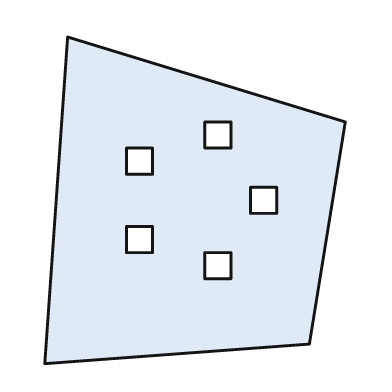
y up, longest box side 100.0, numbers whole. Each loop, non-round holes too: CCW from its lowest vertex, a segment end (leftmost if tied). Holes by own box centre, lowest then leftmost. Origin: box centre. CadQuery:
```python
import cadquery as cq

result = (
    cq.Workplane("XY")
    .moveTo(-46.0, -50.0)
    .lineTo(35.0, -44.0)
    .lineTo(46.0, 24.0)
    .lineTo(-39.0, 50.0)
    .close()
    .moveTo(3.0, -24.0)
    .lineTo(11.0, -24.0)
    .lineTo(11.0, -16.0)
    .lineTo(3.0, -16.0)
    .close()
    .moveTo(-21.0, -16.0)
    .lineTo(-13.0, -16.0)
    .lineTo(-13.0, -8.0)
    .lineTo(-21.0, -8.0)
    .close()
    .moveTo(17.0, -4.0)
    .lineTo(25.0, -4.0)
    .lineTo(25.0, 4.0)
    .lineTo(17.0, 4.0)
    .close()
    .moveTo(-21.0, 8.0)
    .lineTo(-13.0, 8.0)
    .lineTo(-13.0, 16.0)
    .lineTo(-21.0, 16.0)
    .close()
    .moveTo(3.0, 16.0)
    .lineTo(11.0, 16.0)
    .lineTo(11.0, 24.0)
    .lineTo(3.0, 24.0)
    .close()
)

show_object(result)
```